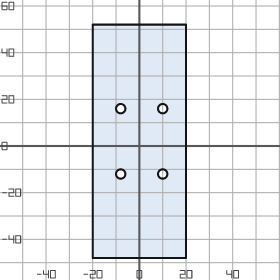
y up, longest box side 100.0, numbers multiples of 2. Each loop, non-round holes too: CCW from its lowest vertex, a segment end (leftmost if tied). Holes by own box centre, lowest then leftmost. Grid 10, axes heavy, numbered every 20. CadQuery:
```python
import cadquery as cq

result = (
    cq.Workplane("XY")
    .moveTo(-20.0, -48.0)
    .lineTo(20.0, -48.0)
    .lineTo(20.0, 52.0)
    .lineTo(-20.0, 52.0)
    .close()
    .moveTo(-8.0, -12.0)
    .circle(2.0)
    .moveTo(10.0, -12.0)
    .circle(2.0)
    .moveTo(-8.0, 16.0)
    .circle(2.0)
    .moveTo(10.0, 16.0)
    .circle(2.0)
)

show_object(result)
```